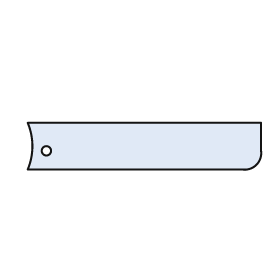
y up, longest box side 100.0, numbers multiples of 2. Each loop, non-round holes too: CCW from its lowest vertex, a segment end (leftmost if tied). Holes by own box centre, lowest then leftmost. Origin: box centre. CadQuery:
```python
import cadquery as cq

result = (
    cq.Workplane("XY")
    .moveTo(-50.0, -10.0)
    .lineTo(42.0, -10.0)
    .threePointArc((48.0, -8.0), (50.0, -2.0))
    .lineTo(50.0, 10.0)
    .lineTo(-50.0, 10.0)
    .threePointArc((-48.0, 0.0), (-50.0, -10.0))
    .close()
    .moveTo(-42.0, -2.0)
    .circle(2.0)
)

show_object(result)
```